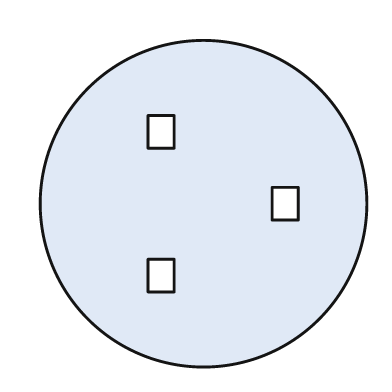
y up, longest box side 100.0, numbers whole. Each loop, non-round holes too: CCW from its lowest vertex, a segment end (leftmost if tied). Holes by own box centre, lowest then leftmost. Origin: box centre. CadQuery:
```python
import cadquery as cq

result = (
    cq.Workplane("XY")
    .moveTo(0.0, 0.0)
    .circle(50.0)
    .moveTo(-17.0, -27.0)
    .lineTo(-9.0, -27.0)
    .lineTo(-9.0, -17.0)
    .lineTo(-17.0, -17.0)
    .close()
    .moveTo(21.0, -5.0)
    .lineTo(29.0, -5.0)
    .lineTo(29.0, 5.0)
    .lineTo(21.0, 5.0)
    .close()
    .moveTo(-17.0, 17.0)
    .lineTo(-9.0, 17.0)
    .lineTo(-9.0, 27.0)
    .lineTo(-17.0, 27.0)
    .close()
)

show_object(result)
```